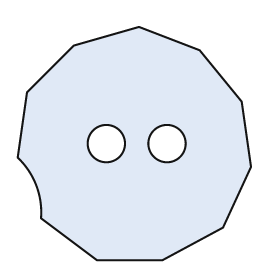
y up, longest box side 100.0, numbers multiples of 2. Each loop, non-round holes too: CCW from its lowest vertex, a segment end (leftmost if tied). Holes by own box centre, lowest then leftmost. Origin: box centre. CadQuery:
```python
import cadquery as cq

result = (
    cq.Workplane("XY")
    .moveTo(-16.0, -50.0)
    .lineTo(12.0, -50.0)
    .lineTo(38.0, -36.0)
    .lineTo(50.0, -10.0)
    .lineTo(46.0, 18.0)
    .lineTo(28.0, 40.0)
    .lineTo(2.0, 50.0)
    .lineTo(-26.0, 42.0)
    .lineTo(-46.0, 22.0)
    .lineTo(-50.0, -6.0)
    .threePointArc((-42.0, -18.0), (-40.0, -32.0))
    .close()
    .moveTo(-12.0, 0.0)
    .circle(8.0)
    .moveTo(14.0, 0.0)
    .circle(8.0)
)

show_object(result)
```